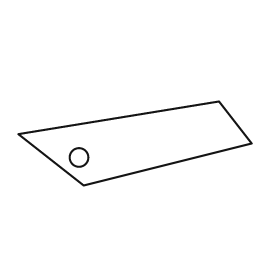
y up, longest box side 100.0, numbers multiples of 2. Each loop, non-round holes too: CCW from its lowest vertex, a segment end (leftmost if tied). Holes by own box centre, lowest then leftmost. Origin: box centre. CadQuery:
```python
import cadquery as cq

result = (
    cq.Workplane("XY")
    .moveTo(-22.0, -18.0)
    .lineTo(50.0, 0.0)
    .lineTo(36.0, 18.0)
    .lineTo(-50.0, 4.0)
    .close()
    .moveTo(-24.0, -6.0)
    .circle(4.0)
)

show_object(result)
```